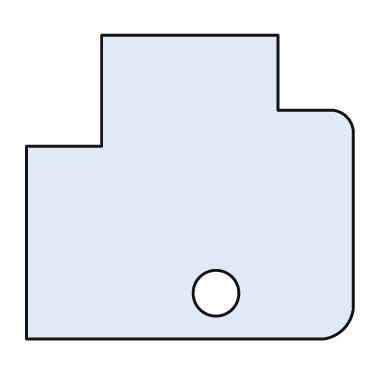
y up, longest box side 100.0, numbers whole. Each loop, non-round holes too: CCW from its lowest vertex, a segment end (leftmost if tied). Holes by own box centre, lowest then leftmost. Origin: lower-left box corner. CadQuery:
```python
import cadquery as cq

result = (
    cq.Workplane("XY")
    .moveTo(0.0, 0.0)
    .lineTo(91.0, 0.0)
    .threePointArc((97.0, 3.0), (100.0, 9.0))
    .lineTo(100.0, 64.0)
    .threePointArc((98.0, 68.0), (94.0, 70.0))
    .lineTo(77.0, 70.0)
    .lineTo(77.0, 93.0)
    .lineTo(23.0, 93.0)
    .lineTo(23.0, 59.0)
    .lineTo(0.0, 59.0)
    .close()
    .moveTo(58.0, 14.0)
    .circle(7.0)
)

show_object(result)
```